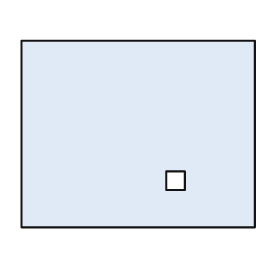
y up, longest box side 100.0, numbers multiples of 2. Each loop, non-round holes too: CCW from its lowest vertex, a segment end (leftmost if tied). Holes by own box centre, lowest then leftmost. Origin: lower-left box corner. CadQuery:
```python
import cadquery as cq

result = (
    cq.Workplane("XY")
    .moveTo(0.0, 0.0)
    .lineTo(100.0, 0.0)
    .lineTo(100.0, 80.0)
    .lineTo(0.0, 80.0)
    .close()
    .moveTo(62.0, 16.0)
    .lineTo(70.0, 16.0)
    .lineTo(70.0, 24.0)
    .lineTo(62.0, 24.0)
    .close()
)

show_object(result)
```